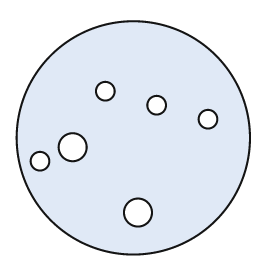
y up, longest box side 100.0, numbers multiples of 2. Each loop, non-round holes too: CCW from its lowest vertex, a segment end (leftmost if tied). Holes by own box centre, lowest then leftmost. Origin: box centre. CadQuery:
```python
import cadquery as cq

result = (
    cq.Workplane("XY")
    .moveTo(0.0, 0.0)
    .circle(50.0)
    .moveTo(2.0, -32.0)
    .circle(6.0)
    .moveTo(-40.0, -10.0)
    .circle(4.0)
    .moveTo(-26.0, -4.0)
    .circle(6.0)
    .moveTo(32.0, 8.0)
    .circle(4.0)
    .moveTo(10.0, 14.0)
    .circle(4.0)
    .moveTo(-12.0, 20.0)
    .circle(4.0)
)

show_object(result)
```